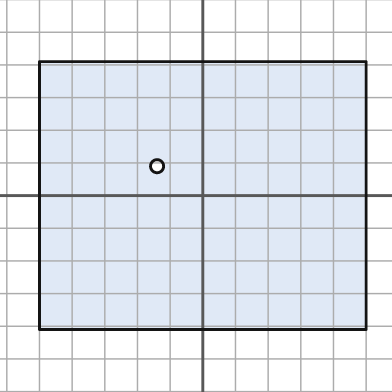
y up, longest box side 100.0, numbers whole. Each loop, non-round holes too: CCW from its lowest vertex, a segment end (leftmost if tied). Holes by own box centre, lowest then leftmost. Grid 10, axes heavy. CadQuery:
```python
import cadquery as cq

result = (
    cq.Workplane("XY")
    .moveTo(-50.0, -41.0)
    .lineTo(50.0, -41.0)
    .lineTo(50.0, 41.0)
    .lineTo(-50.0, 41.0)
    .close()
    .moveTo(-14.0, 9.0)
    .circle(2.0)
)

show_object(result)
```